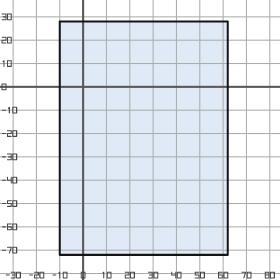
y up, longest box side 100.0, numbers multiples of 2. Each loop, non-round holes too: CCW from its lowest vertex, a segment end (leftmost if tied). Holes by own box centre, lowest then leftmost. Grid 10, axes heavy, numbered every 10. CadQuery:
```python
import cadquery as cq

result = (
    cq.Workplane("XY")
    .moveTo(-10.0, -72.0)
    .lineTo(62.0, -72.0)
    .lineTo(62.0, 28.0)
    .lineTo(-10.0, 28.0)
    .close()
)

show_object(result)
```